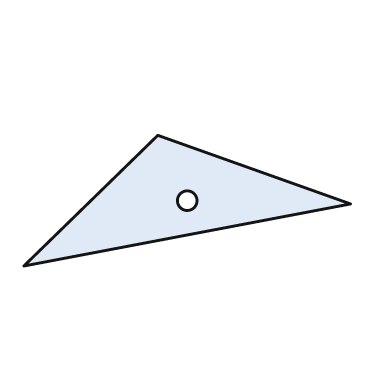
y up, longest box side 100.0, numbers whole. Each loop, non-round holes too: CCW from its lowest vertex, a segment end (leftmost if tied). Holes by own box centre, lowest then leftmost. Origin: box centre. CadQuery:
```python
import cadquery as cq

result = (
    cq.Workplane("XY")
    .moveTo(-50.0, -20.0)
    .lineTo(50.0, -1.0)
    .lineTo(-9.0, 20.0)
    .close()
    .moveTo(0.0, 0.0)
    .circle(3.0)
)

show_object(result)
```